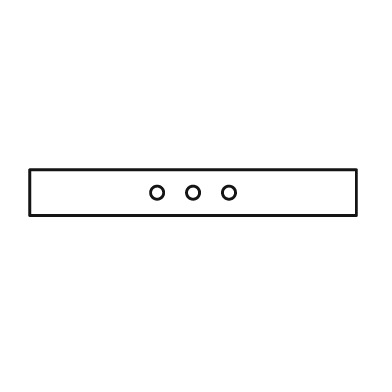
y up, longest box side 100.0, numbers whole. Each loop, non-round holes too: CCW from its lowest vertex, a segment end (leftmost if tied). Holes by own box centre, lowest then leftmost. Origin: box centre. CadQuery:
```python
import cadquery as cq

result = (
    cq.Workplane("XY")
    .moveTo(-50.0, -7.0)
    .lineTo(50.0, -7.0)
    .lineTo(50.0, 7.0)
    .lineTo(-50.0, 7.0)
    .close()
    .moveTo(-11.0, 0.0)
    .circle(2.0)
    .moveTo(0.0, 0.0)
    .circle(2.0)
    .moveTo(11.0, 0.0)
    .circle(2.0)
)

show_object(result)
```